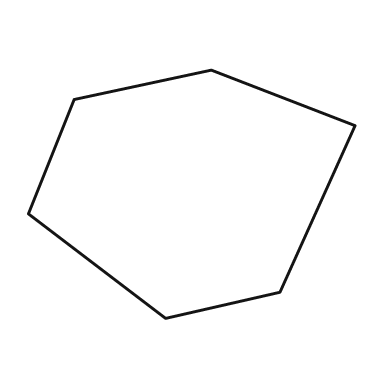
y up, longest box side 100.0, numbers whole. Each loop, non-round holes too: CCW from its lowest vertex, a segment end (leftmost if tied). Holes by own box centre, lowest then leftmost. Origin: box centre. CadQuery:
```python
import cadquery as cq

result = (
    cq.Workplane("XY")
    .moveTo(-8.0, -38.0)
    .lineTo(27.0, -30.0)
    .lineTo(50.0, 21.0)
    .lineTo(6.0, 38.0)
    .lineTo(-36.0, 29.0)
    .lineTo(-50.0, -6.0)
    .close()
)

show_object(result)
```